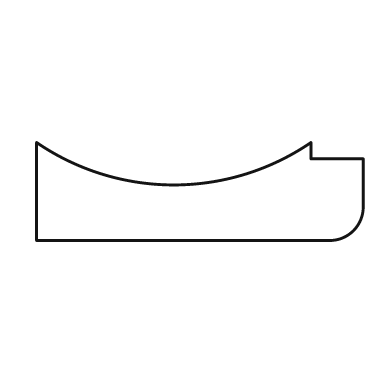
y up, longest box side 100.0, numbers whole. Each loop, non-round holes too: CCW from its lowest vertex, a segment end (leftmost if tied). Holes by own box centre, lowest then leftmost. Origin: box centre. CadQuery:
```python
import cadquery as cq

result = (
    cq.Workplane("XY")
    .moveTo(-50.0, -15.0)
    .lineTo(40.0, -15.0)
    .threePointArc((47.0, -12.0), (50.0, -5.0))
    .lineTo(50.0, 10.0)
    .lineTo(34.0, 10.0)
    .lineTo(34.0, 15.0)
    .threePointArc((-8.0, 2.0), (-50.0, 15.0))
    .close()
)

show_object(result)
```